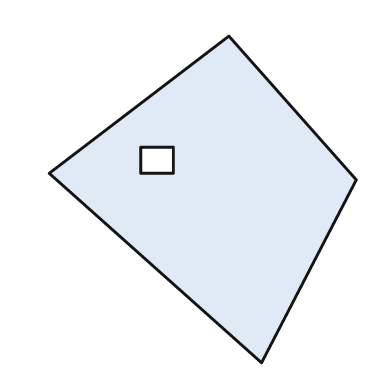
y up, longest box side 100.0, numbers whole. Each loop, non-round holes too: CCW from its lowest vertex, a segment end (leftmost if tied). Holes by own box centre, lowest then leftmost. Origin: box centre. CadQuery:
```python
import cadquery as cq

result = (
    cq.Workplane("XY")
    .moveTo(18.0, -50.0)
    .lineTo(47.0, 6.0)
    .lineTo(8.0, 50.0)
    .lineTo(-47.0, 8.0)
    .close()
    .moveTo(-19.0, 8.0)
    .lineTo(-9.0, 8.0)
    .lineTo(-9.0, 16.0)
    .lineTo(-19.0, 16.0)
    .close()
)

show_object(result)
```